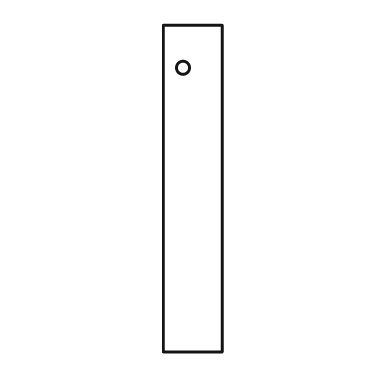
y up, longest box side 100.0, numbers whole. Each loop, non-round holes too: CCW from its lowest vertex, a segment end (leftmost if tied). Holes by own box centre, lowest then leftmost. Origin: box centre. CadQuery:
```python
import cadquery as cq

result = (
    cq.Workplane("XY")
    .moveTo(-9.0, -50.0)
    .lineTo(9.0, -50.0)
    .lineTo(9.0, 50.0)
    .lineTo(-9.0, 50.0)
    .close()
    .moveTo(-3.0, 37.0)
    .circle(2.0)
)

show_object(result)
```